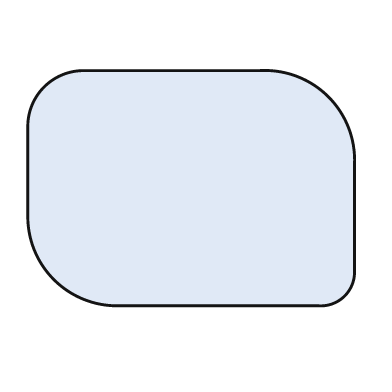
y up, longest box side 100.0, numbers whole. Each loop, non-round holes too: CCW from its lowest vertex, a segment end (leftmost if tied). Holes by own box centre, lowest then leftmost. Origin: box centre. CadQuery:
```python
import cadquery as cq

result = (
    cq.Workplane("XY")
    .moveTo(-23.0, -36.0)
    .lineTo(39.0, -36.0)
    .threePointArc((47.0, -33.0), (50.0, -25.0))
    .lineTo(50.0, 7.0)
    .threePointArc((42.0, 28.0), (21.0, 36.0))
    .lineTo(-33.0, 36.0)
    .threePointArc((-45.0, 31.0), (-50.0, 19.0))
    .lineTo(-50.0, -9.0)
    .threePointArc((-42.0, -28.0), (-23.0, -36.0))
    .close()
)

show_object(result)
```